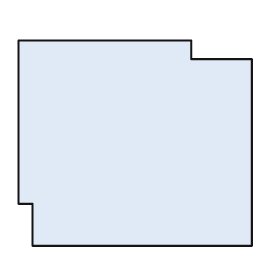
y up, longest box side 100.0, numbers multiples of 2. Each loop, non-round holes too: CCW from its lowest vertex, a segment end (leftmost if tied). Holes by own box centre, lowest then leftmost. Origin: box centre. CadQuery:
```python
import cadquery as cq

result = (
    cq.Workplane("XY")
    .moveTo(-44.0, -44.0)
    .lineTo(50.0, -44.0)
    .lineTo(50.0, 36.0)
    .lineTo(24.0, 36.0)
    .lineTo(24.0, 44.0)
    .lineTo(-50.0, 44.0)
    .lineTo(-50.0, -26.0)
    .lineTo(-44.0, -26.0)
    .close()
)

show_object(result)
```